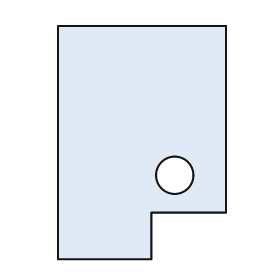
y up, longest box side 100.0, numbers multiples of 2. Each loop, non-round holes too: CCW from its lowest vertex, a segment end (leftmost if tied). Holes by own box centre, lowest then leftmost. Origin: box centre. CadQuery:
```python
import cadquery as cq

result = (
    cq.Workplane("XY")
    .moveTo(-36.0, -50.0)
    .lineTo(4.0, -50.0)
    .lineTo(4.0, -30.0)
    .lineTo(36.0, -30.0)
    .lineTo(36.0, 50.0)
    .lineTo(-36.0, 50.0)
    .close()
    .moveTo(14.0, -14.0)
    .circle(8.0)
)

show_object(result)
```